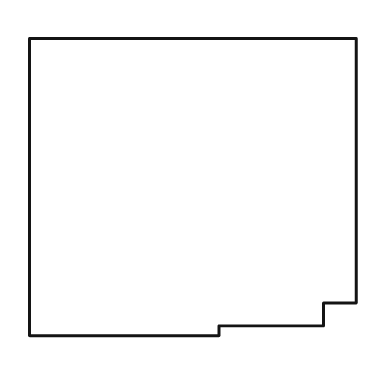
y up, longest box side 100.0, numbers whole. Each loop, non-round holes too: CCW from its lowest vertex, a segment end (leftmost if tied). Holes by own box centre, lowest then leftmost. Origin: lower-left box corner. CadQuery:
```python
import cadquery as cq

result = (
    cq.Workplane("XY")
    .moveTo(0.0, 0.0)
    .lineTo(58.0, 0.0)
    .lineTo(58.0, 3.0)
    .lineTo(90.0, 3.0)
    .lineTo(90.0, 10.0)
    .lineTo(100.0, 10.0)
    .lineTo(100.0, 91.0)
    .lineTo(0.0, 91.0)
    .close()
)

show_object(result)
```